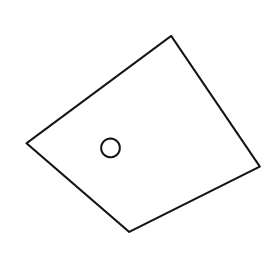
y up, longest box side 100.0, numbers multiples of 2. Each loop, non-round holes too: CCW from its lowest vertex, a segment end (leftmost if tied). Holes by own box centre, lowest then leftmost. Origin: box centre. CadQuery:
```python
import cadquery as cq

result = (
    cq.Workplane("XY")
    .moveTo(-6.0, -42.0)
    .lineTo(50.0, -14.0)
    .lineTo(12.0, 42.0)
    .lineTo(-50.0, -4.0)
    .close()
    .moveTo(-14.0, -6.0)
    .circle(4.0)
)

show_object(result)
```